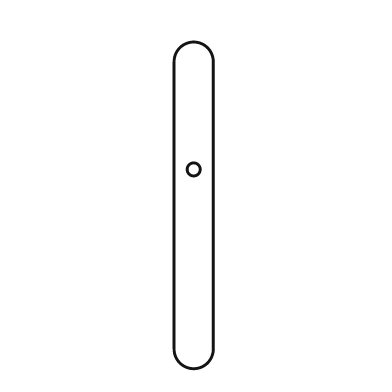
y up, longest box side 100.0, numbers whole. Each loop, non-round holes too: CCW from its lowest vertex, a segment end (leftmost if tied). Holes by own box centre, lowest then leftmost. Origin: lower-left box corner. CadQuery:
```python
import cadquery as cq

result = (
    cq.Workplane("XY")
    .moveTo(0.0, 6.0)
    .threePointArc((6.0, 0.0), (12.0, 6.0))
    .lineTo(12.0, 94.0)
    .threePointArc((6.0, 100.0), (0.0, 94.0))
    .close()
    .moveTo(6.0, 61.0)
    .circle(2.0)
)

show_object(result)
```